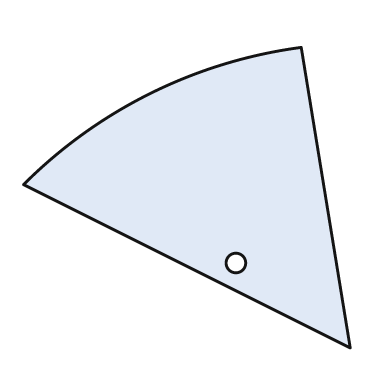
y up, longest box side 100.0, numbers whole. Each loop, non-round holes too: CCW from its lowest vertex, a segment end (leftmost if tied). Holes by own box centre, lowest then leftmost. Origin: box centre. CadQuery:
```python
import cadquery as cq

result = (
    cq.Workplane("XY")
    .moveTo(50.0, -46.0)
    .lineTo(35.0, 46.0)
    .threePointArc((-11.0, 32.0), (-50.0, 4.0))
    .close()
    .moveTo(15.0, -20.0)
    .circle(3.0)
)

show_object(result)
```